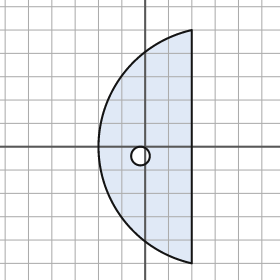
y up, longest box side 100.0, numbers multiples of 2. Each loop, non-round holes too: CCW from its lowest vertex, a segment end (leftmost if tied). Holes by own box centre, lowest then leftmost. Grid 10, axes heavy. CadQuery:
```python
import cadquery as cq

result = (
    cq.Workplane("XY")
    .moveTo(20.0, -50.0)
    .lineTo(20.0, 50.0)
    .threePointArc((-20.0, 0.0), (20.0, -50.0))
    .close()
    .moveTo(-2.0, -4.0)
    .circle(4.0)
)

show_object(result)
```